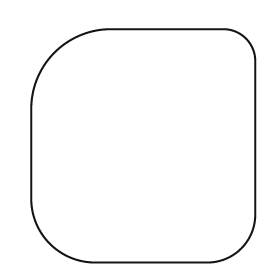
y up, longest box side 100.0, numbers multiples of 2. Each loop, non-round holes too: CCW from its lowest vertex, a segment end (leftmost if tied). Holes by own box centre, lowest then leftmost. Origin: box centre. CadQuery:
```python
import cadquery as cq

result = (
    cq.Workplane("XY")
    .moveTo(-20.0, -50.0)
    .lineTo(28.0, -50.0)
    .threePointArc((42.0, -44.0), (48.0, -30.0))
    .lineTo(48.0, 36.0)
    .threePointArc((44.0, 46.0), (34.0, 50.0))
    .lineTo(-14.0, 50.0)
    .threePointArc((-38.0, 40.0), (-48.0, 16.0))
    .lineTo(-48.0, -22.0)
    .threePointArc((-40.0, -42.0), (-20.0, -50.0))
    .close()
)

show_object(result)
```